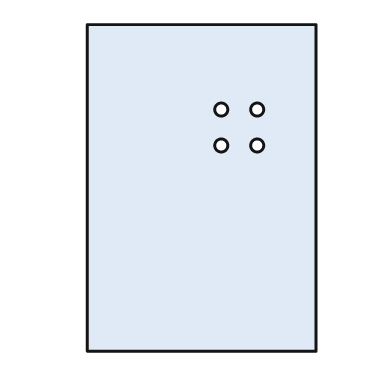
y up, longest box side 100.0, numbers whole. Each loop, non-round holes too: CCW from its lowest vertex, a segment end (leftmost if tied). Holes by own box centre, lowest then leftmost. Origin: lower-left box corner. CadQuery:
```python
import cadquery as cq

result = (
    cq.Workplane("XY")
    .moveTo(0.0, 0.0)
    .lineTo(70.0, 0.0)
    .lineTo(70.0, 100.0)
    .lineTo(0.0, 100.0)
    .close()
    .moveTo(41.0, 63.0)
    .circle(2.0)
    .moveTo(52.0, 63.0)
    .circle(2.0)
    .moveTo(41.0, 74.0)
    .circle(2.0)
    .moveTo(52.0, 74.0)
    .circle(2.0)
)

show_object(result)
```